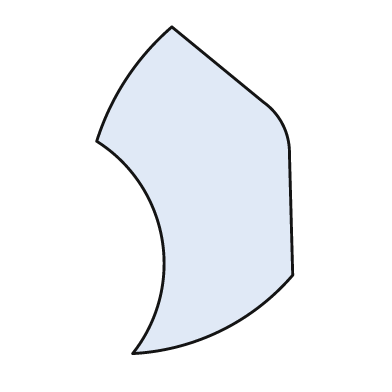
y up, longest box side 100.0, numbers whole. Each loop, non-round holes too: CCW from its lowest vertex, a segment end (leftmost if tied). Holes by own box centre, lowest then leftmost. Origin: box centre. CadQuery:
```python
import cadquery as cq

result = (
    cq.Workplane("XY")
    .moveTo(-19.0, -50.0)
    .threePointArc((8.0, -43.0), (30.0, -26.0))
    .lineTo(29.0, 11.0)
    .threePointArc((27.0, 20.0), (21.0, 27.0))
    .lineTo(-7.0, 50.0)
    .threePointArc((-21.0, 34.0), (-30.0, 15.0))
    .threePointArc((-10.0, -15.0), (-19.0, -50.0))
    .close()
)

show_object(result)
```